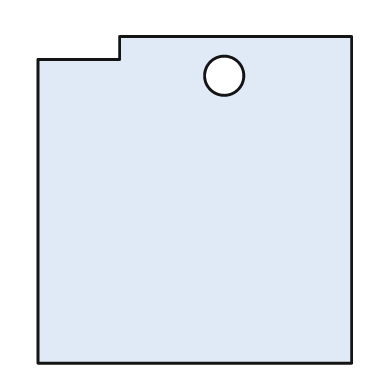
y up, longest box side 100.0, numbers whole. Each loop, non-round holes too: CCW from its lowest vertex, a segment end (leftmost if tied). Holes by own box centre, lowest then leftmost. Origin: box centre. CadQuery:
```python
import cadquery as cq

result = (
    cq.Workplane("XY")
    .moveTo(-48.0, -50.0)
    .lineTo(48.0, -50.0)
    .lineTo(48.0, 50.0)
    .lineTo(-23.0, 50.0)
    .lineTo(-23.0, 43.0)
    .lineTo(-48.0, 43.0)
    .close()
    .moveTo(9.0, 38.0)
    .circle(6.0)
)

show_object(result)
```